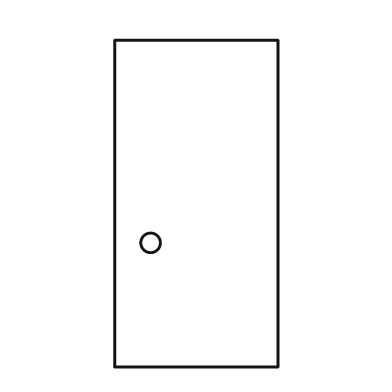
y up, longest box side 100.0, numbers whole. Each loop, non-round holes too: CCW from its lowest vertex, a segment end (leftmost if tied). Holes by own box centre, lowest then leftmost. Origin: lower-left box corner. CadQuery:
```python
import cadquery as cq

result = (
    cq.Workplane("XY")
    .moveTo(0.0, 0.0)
    .lineTo(50.0, 0.0)
    .lineTo(50.0, 100.0)
    .lineTo(0.0, 100.0)
    .close()
    .moveTo(11.0, 38.0)
    .circle(3.0)
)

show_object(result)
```